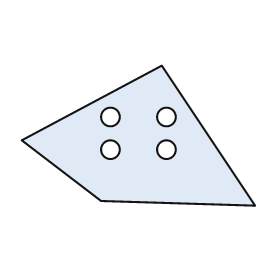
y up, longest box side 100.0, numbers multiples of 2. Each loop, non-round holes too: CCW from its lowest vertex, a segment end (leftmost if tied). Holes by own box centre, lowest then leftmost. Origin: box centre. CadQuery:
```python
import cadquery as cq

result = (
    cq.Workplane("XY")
    .moveTo(50.0, -30.0)
    .lineTo(10.0, 30.0)
    .lineTo(-50.0, -2.0)
    .lineTo(-16.0, -28.0)
    .close()
    .moveTo(-12.0, -6.0)
    .circle(4.0)
    .moveTo(12.0, -6.0)
    .circle(4.0)
    .moveTo(-12.0, 8.0)
    .circle(4.0)
    .moveTo(12.0, 8.0)
    .circle(4.0)
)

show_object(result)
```